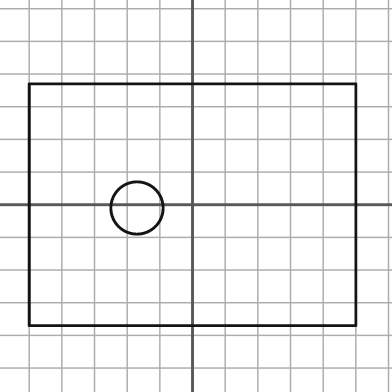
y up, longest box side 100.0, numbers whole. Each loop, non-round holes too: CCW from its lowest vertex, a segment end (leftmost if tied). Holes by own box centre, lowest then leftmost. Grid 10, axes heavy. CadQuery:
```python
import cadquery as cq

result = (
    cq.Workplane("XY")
    .moveTo(-50.0, -37.0)
    .lineTo(50.0, -37.0)
    .lineTo(50.0, 37.0)
    .lineTo(-50.0, 37.0)
    .close()
    .moveTo(-17.0, -1.0)
    .circle(8.0)
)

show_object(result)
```